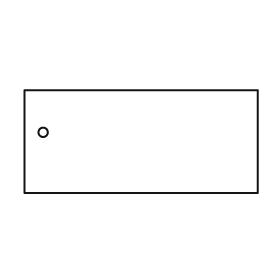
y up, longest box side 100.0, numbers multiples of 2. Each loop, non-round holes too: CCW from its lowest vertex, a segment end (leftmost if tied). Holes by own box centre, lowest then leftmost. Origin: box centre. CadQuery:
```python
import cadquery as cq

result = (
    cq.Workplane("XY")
    .moveTo(-50.0, -22.0)
    .lineTo(50.0, -22.0)
    .lineTo(50.0, 22.0)
    .lineTo(-50.0, 22.0)
    .close()
    .moveTo(-42.0, 4.0)
    .circle(2.0)
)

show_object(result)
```